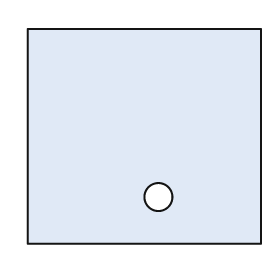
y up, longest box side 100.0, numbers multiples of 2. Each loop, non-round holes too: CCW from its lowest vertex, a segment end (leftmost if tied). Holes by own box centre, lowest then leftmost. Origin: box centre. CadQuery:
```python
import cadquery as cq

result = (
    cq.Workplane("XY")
    .moveTo(-50.0, -46.0)
    .lineTo(50.0, -46.0)
    .lineTo(50.0, 46.0)
    .lineTo(-50.0, 46.0)
    .close()
    .moveTo(6.0, -26.0)
    .circle(6.0)
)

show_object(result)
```